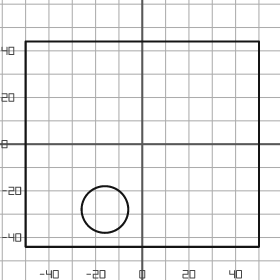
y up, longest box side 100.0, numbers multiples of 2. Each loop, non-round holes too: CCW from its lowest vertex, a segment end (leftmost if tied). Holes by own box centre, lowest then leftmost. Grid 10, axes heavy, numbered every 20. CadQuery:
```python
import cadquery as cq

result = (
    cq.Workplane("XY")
    .moveTo(-50.0, -44.0)
    .lineTo(50.0, -44.0)
    .lineTo(50.0, 44.0)
    .lineTo(-50.0, 44.0)
    .close()
    .moveTo(-16.0, -28.0)
    .circle(10.0)
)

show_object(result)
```